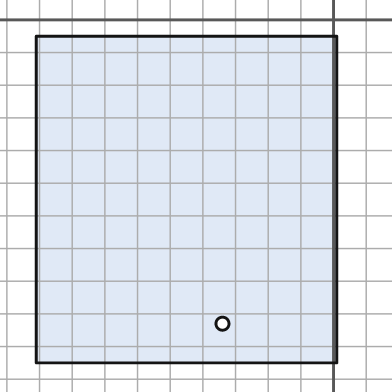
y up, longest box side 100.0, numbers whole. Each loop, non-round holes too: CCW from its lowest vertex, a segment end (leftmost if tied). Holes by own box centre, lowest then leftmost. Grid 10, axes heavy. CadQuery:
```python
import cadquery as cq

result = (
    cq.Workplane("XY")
    .moveTo(-91.0, -105.0)
    .lineTo(1.0, -105.0)
    .lineTo(1.0, -5.0)
    .lineTo(-91.0, -5.0)
    .close()
    .moveTo(-34.0, -93.0)
    .circle(2.0)
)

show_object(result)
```